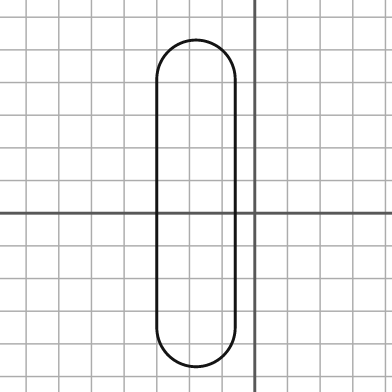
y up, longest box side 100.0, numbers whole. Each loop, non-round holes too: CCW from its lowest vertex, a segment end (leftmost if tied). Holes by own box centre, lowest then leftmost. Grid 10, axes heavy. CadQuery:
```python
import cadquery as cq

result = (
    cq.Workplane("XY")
    .moveTo(-30.0, -35.0)
    .threePointArc((-18.0, -47.0), (-6.0, -35.0))
    .lineTo(-6.0, 41.0)
    .threePointArc((-18.0, 53.0), (-30.0, 41.0))
    .close()
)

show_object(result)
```